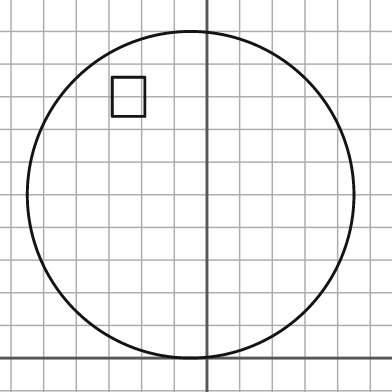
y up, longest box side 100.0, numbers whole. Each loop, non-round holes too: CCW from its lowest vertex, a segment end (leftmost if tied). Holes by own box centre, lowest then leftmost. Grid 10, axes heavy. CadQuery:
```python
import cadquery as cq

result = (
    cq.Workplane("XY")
    .moveTo(-5.0, 50.0)
    .circle(50.0)
    .moveTo(-29.0, 74.0)
    .lineTo(-19.0, 74.0)
    .lineTo(-19.0, 86.0)
    .lineTo(-29.0, 86.0)
    .close()
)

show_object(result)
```